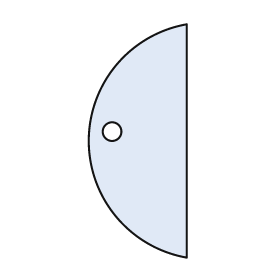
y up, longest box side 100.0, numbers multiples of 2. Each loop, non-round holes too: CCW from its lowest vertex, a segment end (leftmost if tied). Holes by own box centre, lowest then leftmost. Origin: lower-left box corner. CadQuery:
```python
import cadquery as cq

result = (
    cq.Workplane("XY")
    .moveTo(42.0, 0.0)
    .lineTo(42.0, 100.0)
    .threePointArc((0.0, 50.0), (42.0, 0.0))
    .close()
    .moveTo(10.0, 54.0)
    .circle(4.0)
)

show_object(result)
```